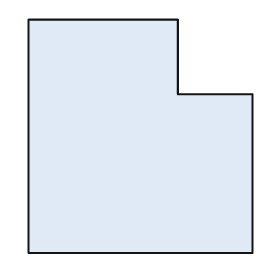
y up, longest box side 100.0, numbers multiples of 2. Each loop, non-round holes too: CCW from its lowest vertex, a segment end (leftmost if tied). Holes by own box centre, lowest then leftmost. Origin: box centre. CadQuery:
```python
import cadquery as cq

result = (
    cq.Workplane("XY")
    .moveTo(-48.0, -50.0)
    .lineTo(48.0, -50.0)
    .lineTo(48.0, 18.0)
    .lineTo(16.0, 18.0)
    .lineTo(16.0, 50.0)
    .lineTo(-48.0, 50.0)
    .close()
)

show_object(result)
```